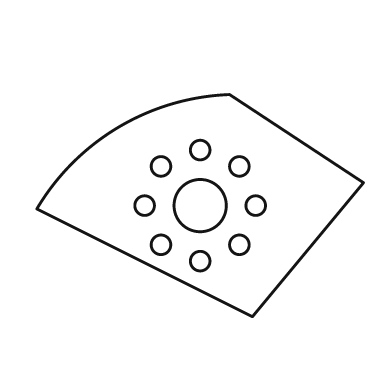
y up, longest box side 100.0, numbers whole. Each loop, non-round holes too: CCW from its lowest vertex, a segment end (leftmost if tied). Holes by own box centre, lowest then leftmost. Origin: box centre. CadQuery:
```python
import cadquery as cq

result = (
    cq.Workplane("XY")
    .moveTo(16.0, -34.0)
    .lineTo(50.0, 7.0)
    .lineTo(9.0, 34.0)
    .threePointArc((-25.0, 24.0), (-50.0, -1.0))
    .close()
    .moveTo(0.0, -17.0)
    .circle(3.0)
    .moveTo(-12.0, -12.0)
    .circle(3.0)
    .moveTo(12.0, -12.0)
    .circle(3.0)
    .moveTo(-17.0, 0.0)
    .circle(3.0)
    .moveTo(0.0, 0.0)
    .circle(8.0)
    .moveTo(17.0, 0.0)
    .circle(3.0)
    .moveTo(-12.0, 12.0)
    .circle(3.0)
    .moveTo(12.0, 12.0)
    .circle(3.0)
    .moveTo(0.0, 17.0)
    .circle(3.0)
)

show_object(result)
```